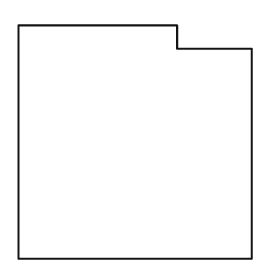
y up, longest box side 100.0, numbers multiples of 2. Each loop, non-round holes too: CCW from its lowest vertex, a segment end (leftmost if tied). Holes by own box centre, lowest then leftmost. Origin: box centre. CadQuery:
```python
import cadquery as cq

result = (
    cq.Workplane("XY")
    .moveTo(-50.0, -50.0)
    .lineTo(50.0, -50.0)
    .lineTo(50.0, 40.0)
    .lineTo(18.0, 40.0)
    .lineTo(18.0, 50.0)
    .lineTo(-50.0, 50.0)
    .close()
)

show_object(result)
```